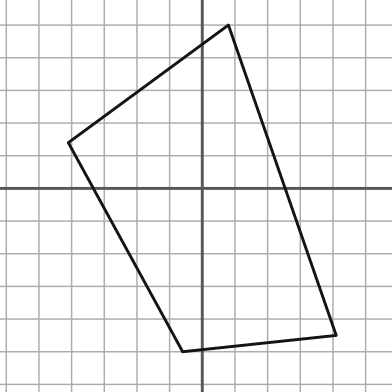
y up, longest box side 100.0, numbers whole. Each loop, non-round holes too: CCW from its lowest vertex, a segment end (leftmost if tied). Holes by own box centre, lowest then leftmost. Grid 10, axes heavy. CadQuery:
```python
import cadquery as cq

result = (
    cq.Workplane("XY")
    .moveTo(-6.0, -50.0)
    .lineTo(41.0, -45.0)
    .lineTo(8.0, 50.0)
    .lineTo(-41.0, 14.0)
    .close()
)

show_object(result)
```